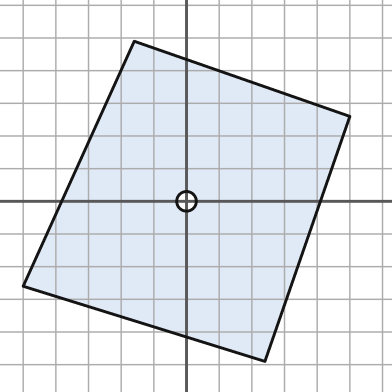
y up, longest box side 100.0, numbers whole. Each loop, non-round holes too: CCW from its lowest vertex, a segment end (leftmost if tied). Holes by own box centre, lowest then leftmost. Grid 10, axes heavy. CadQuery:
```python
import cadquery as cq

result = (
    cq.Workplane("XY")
    .moveTo(24.0, -49.0)
    .lineTo(50.0, 26.0)
    .lineTo(-16.0, 49.0)
    .lineTo(-50.0, -26.0)
    .close()
    .moveTo(0.0, 0.0)
    .circle(3.0)
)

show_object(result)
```